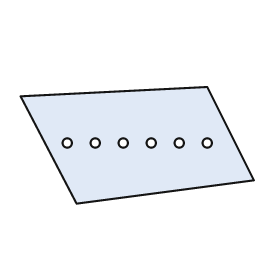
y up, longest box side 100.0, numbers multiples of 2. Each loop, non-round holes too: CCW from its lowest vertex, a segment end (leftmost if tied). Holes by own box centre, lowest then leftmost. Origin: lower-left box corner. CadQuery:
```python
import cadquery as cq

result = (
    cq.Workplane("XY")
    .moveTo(24.0, 0.0)
    .lineTo(100.0, 10.0)
    .lineTo(80.0, 50.0)
    .lineTo(0.0, 46.0)
    .close()
    .moveTo(20.0, 26.0)
    .circle(2.0)
    .moveTo(32.0, 26.0)
    .circle(2.0)
    .moveTo(44.0, 26.0)
    .circle(2.0)
    .moveTo(56.0, 26.0)
    .circle(2.0)
    .moveTo(68.0, 26.0)
    .circle(2.0)
    .moveTo(80.0, 26.0)
    .circle(2.0)
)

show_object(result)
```